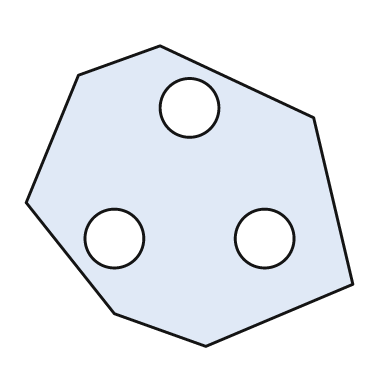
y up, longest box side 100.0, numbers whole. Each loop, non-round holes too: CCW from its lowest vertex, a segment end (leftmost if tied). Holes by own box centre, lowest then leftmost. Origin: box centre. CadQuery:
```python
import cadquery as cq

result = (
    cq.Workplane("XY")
    .moveTo(5.0, -46.0)
    .lineTo(50.0, -27.0)
    .lineTo(38.0, 24.0)
    .lineTo(-9.0, 46.0)
    .lineTo(-34.0, 37.0)
    .lineTo(-50.0, -2.0)
    .lineTo(-23.0, -36.0)
    .close()
    .moveTo(-23.0, -13.0)
    .circle(9.0)
    .moveTo(23.0, -13.0)
    .circle(9.0)
    .moveTo(0.0, 27.0)
    .circle(9.0)
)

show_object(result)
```